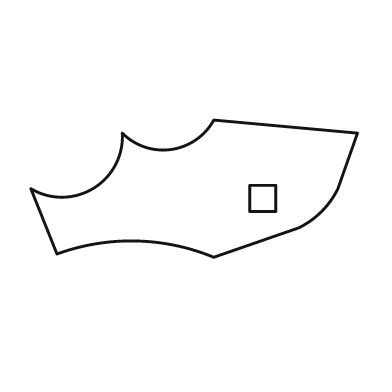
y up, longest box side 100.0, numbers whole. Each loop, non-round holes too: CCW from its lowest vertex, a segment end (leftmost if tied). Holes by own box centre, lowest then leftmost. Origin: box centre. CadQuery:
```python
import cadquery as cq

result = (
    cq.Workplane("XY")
    .moveTo(6.0, -21.0)
    .lineTo(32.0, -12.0)
    .threePointArc((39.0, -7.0), (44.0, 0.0))
    .lineTo(50.0, 17.0)
    .lineTo(6.0, 21.0)
    .threePointArc((-7.0, 12.0), (-22.0, 17.0))
    .threePointArc((-31.0, 0.0), (-50.0, 0.0))
    .lineTo(-42.0, -20.0)
    .threePointArc((-18.0, -16.0), (6.0, -21.0))
    .close()
    .moveTo(17.0, -7.0)
    .lineTo(25.0, -7.0)
    .lineTo(25.0, 1.0)
    .lineTo(17.0, 1.0)
    .close()
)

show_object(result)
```